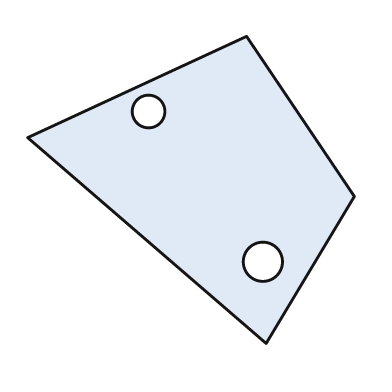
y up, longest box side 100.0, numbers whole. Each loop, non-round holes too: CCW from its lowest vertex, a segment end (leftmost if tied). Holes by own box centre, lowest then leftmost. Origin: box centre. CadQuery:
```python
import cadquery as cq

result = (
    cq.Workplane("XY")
    .moveTo(23.0, -47.0)
    .lineTo(50.0, -2.0)
    .lineTo(17.0, 47.0)
    .lineTo(-50.0, 16.0)
    .close()
    .moveTo(22.0, -22.0)
    .circle(6.0)
    .moveTo(-13.0, 24.0)
    .circle(5.0)
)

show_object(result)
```